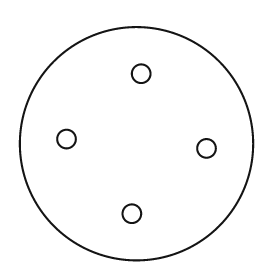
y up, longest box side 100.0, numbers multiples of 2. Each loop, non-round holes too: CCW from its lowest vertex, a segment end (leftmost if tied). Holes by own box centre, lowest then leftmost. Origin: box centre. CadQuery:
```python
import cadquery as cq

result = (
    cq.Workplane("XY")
    .moveTo(0.0, 0.0)
    .circle(50.0)
    .moveTo(-2.0, -30.0)
    .circle(4.0)
    .moveTo(30.0, -2.0)
    .circle(4.0)
    .moveTo(-30.0, 2.0)
    .circle(4.0)
    .moveTo(2.0, 30.0)
    .circle(4.0)
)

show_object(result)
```